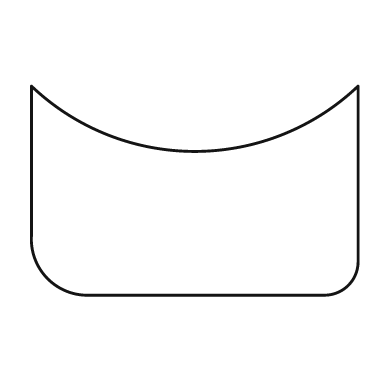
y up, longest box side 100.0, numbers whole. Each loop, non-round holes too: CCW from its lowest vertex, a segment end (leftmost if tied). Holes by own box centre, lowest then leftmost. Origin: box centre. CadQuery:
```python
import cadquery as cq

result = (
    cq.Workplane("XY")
    .moveTo(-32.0, -32.0)
    .lineTo(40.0, -32.0)
    .threePointArc((47.0, -29.0), (50.0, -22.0))
    .lineTo(50.0, 32.0)
    .threePointArc((0.0, 12.0), (-50.0, 32.0))
    .lineTo(-50.0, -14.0)
    .threePointArc((-45.0, -27.0), (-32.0, -32.0))
    .close()
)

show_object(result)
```